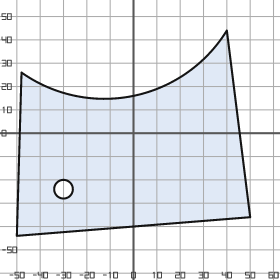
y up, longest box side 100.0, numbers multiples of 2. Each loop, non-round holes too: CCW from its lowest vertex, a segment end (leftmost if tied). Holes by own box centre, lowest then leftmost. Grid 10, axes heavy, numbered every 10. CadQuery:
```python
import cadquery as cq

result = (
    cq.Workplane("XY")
    .moveTo(-50.0, -44.0)
    .lineTo(50.0, -36.0)
    .lineTo(40.0, 44.0)
    .threePointArc((0.0, 16.0), (-48.0, 26.0))
    .close()
    .moveTo(-30.0, -24.0)
    .circle(4.0)
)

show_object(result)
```